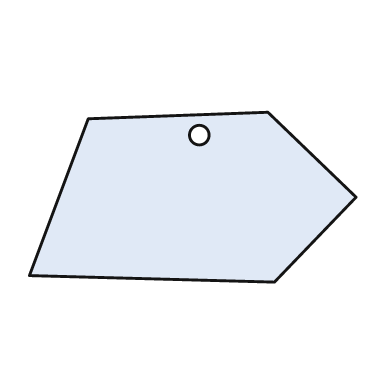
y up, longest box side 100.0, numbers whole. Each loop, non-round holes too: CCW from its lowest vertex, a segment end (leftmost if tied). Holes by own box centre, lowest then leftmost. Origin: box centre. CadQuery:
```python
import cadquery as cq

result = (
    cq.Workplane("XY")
    .moveTo(25.0, -26.0)
    .lineTo(50.0, 0.0)
    .lineTo(23.0, 26.0)
    .lineTo(-32.0, 24.0)
    .lineTo(-50.0, -24.0)
    .close()
    .moveTo(2.0, 19.0)
    .circle(3.0)
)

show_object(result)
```